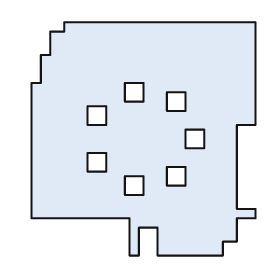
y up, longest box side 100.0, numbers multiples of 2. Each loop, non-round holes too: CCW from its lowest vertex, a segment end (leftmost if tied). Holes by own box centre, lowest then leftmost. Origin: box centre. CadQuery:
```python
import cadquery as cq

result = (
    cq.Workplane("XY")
    .moveTo(-6.0, -50.0)
    .lineTo(-2.0, -50.0)
    .lineTo(-2.0, -38.0)
    .lineTo(6.0, -38.0)
    .lineTo(6.0, -50.0)
    .lineTo(34.0, -50.0)
    .lineTo(34.0, -44.0)
    .lineTo(40.0, -44.0)
    .lineTo(40.0, -34.0)
    .lineTo(48.0, -34.0)
    .lineTo(48.0, -30.0)
    .lineTo(40.0, -30.0)
    .lineTo(40.0, 6.0)
    .lineTo(48.0, 6.0)
    .lineTo(48.0, 50.0)
    .lineTo(-34.0, 50.0)
    .lineTo(-34.0, 46.0)
    .lineTo(-40.0, 46.0)
    .lineTo(-40.0, 36.0)
    .lineTo(-44.0, 36.0)
    .lineTo(-44.0, 24.0)
    .lineTo(-48.0, 24.0)
    .lineTo(-48.0, -34.0)
    .lineTo(-6.0, -34.0)
    .close()
    .moveTo(-8.0, -24.0)
    .lineTo(0.0, -24.0)
    .lineTo(0.0, -16.0)
    .lineTo(-8.0, -16.0)
    .close()
    .moveTo(10.0, -20.0)
    .lineTo(18.0, -20.0)
    .lineTo(18.0, -12.0)
    .lineTo(10.0, -12.0)
    .close()
    .moveTo(-24.0, -14.0)
    .lineTo(-16.0, -14.0)
    .lineTo(-16.0, -6.0)
    .lineTo(-24.0, -6.0)
    .close()
    .moveTo(18.0, -4.0)
    .lineTo(26.0, -4.0)
    .lineTo(26.0, 4.0)
    .lineTo(18.0, 4.0)
    .close()
    .moveTo(-24.0, 6.0)
    .lineTo(-16.0, 6.0)
    .lineTo(-16.0, 14.0)
    .lineTo(-24.0, 14.0)
    .close()
    .moveTo(10.0, 12.0)
    .lineTo(18.0, 12.0)
    .lineTo(18.0, 20.0)
    .lineTo(10.0, 20.0)
    .close()
    .moveTo(-8.0, 16.0)
    .lineTo(0.0, 16.0)
    .lineTo(0.0, 24.0)
    .lineTo(-8.0, 24.0)
    .close()
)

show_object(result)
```